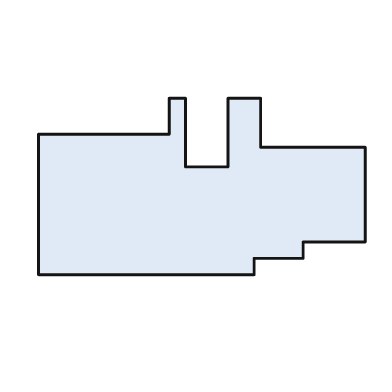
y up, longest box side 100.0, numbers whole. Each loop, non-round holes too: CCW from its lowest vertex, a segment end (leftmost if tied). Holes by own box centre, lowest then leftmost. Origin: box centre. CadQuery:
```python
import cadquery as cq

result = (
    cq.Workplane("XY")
    .moveTo(-50.0, -27.0)
    .lineTo(16.0, -27.0)
    .lineTo(16.0, -22.0)
    .lineTo(31.0, -22.0)
    .lineTo(31.0, -17.0)
    .lineTo(50.0, -17.0)
    .lineTo(50.0, 12.0)
    .lineTo(18.0, 12.0)
    .lineTo(18.0, 27.0)
    .lineTo(8.0, 27.0)
    .lineTo(8.0, 6.0)
    .lineTo(-5.0, 6.0)
    .lineTo(-5.0, 27.0)
    .lineTo(-10.0, 27.0)
    .lineTo(-10.0, 16.0)
    .lineTo(-50.0, 16.0)
    .close()
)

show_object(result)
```